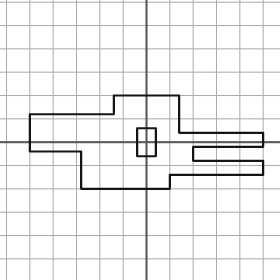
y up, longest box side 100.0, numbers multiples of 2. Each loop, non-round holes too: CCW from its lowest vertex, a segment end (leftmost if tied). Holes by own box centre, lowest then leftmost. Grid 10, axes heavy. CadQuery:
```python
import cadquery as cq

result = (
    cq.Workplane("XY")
    .moveTo(-28.0, -20.0)
    .lineTo(10.0, -20.0)
    .lineTo(10.0, -14.0)
    .lineTo(50.0, -14.0)
    .lineTo(50.0, -8.0)
    .lineTo(20.0, -8.0)
    .lineTo(20.0, -2.0)
    .lineTo(50.0, -2.0)
    .lineTo(50.0, 4.0)
    .lineTo(14.0, 4.0)
    .lineTo(14.0, 20.0)
    .lineTo(-14.0, 20.0)
    .lineTo(-14.0, 12.0)
    .lineTo(-50.0, 12.0)
    .lineTo(-50.0, -4.0)
    .lineTo(-28.0, -4.0)
    .close()
    .moveTo(-4.0, -6.0)
    .lineTo(4.0, -6.0)
    .lineTo(4.0, 6.0)
    .lineTo(-4.0, 6.0)
    .close()
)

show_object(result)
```